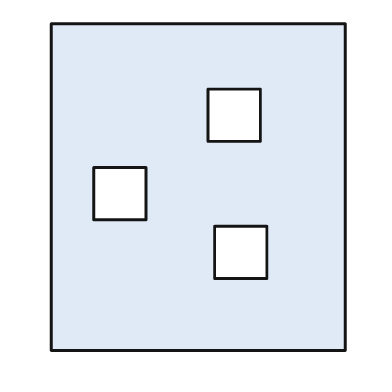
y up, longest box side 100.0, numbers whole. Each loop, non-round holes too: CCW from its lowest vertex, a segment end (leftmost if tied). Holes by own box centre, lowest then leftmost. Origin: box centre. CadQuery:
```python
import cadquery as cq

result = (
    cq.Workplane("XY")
    .moveTo(-45.0, -50.0)
    .lineTo(45.0, -50.0)
    .lineTo(45.0, 50.0)
    .lineTo(-45.0, 50.0)
    .close()
    .moveTo(5.0, -28.0)
    .lineTo(21.0, -28.0)
    .lineTo(21.0, -12.0)
    .lineTo(5.0, -12.0)
    .close()
    .moveTo(-32.0, -10.0)
    .lineTo(-16.0, -10.0)
    .lineTo(-16.0, 6.0)
    .lineTo(-32.0, 6.0)
    .close()
    .moveTo(3.0, 14.0)
    .lineTo(19.0, 14.0)
    .lineTo(19.0, 30.0)
    .lineTo(3.0, 30.0)
    .close()
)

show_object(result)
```